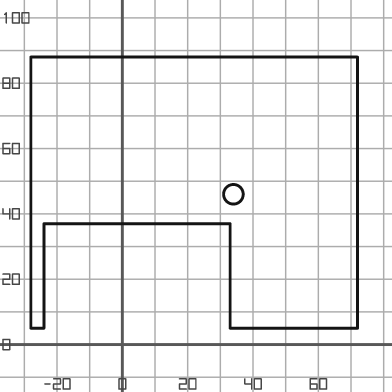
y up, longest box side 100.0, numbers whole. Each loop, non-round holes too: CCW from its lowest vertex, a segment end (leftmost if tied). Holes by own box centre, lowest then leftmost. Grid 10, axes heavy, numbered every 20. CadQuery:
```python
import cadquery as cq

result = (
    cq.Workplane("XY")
    .moveTo(-28.0, 5.0)
    .lineTo(-24.0, 5.0)
    .lineTo(-24.0, 37.0)
    .lineTo(33.0, 37.0)
    .lineTo(33.0, 5.0)
    .lineTo(72.0, 5.0)
    .lineTo(72.0, 88.0)
    .lineTo(-28.0, 88.0)
    .close()
    .moveTo(34.0, 46.0)
    .circle(3.0)
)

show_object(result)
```